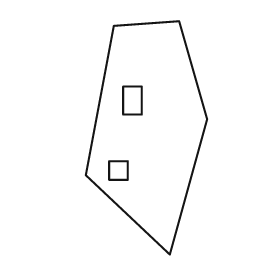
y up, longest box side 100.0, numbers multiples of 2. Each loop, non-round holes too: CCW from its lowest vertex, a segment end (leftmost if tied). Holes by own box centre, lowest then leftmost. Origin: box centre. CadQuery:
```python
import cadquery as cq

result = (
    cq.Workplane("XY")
    .moveTo(10.0, -50.0)
    .lineTo(26.0, 8.0)
    .lineTo(14.0, 50.0)
    .lineTo(-14.0, 48.0)
    .lineTo(-26.0, -16.0)
    .close()
    .moveTo(-16.0, -18.0)
    .lineTo(-8.0, -18.0)
    .lineTo(-8.0, -10.0)
    .lineTo(-16.0, -10.0)
    .close()
    .moveTo(-10.0, 10.0)
    .lineTo(-2.0, 10.0)
    .lineTo(-2.0, 22.0)
    .lineTo(-10.0, 22.0)
    .close()
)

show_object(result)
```